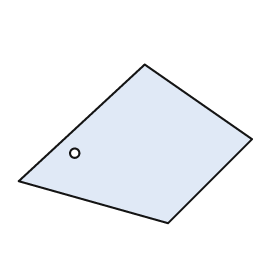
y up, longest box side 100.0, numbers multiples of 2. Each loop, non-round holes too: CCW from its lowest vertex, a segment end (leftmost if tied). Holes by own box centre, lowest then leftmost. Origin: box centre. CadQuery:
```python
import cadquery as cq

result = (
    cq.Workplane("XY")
    .moveTo(14.0, -34.0)
    .lineTo(50.0, 2.0)
    .lineTo(4.0, 34.0)
    .lineTo(-50.0, -16.0)
    .close()
    .moveTo(-26.0, -4.0)
    .circle(2.0)
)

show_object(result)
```